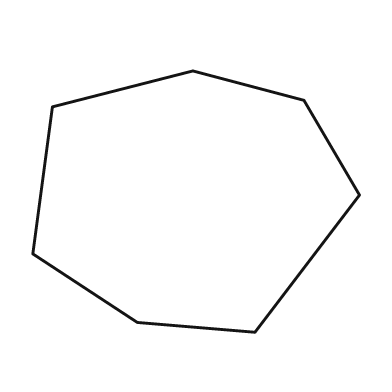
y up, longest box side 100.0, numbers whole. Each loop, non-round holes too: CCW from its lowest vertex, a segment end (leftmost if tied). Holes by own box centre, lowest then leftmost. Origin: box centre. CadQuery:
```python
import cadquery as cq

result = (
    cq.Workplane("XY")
    .moveTo(18.0, -40.0)
    .lineTo(50.0, 2.0)
    .lineTo(33.0, 31.0)
    .lineTo(-1.0, 40.0)
    .lineTo(-44.0, 29.0)
    .lineTo(-50.0, -16.0)
    .lineTo(-18.0, -37.0)
    .close()
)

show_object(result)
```